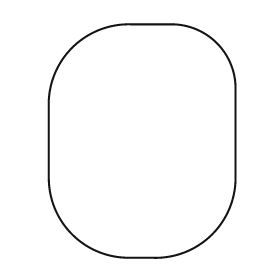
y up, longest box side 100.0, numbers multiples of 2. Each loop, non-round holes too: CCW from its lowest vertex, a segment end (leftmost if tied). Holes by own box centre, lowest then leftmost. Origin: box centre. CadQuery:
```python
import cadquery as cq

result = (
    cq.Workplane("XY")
    .moveTo(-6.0, -50.0)
    .lineTo(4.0, -50.0)
    .threePointArc((30.0, -40.0), (40.0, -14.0))
    .lineTo(40.0, 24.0)
    .threePointArc((32.0, 42.0), (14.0, 50.0))
    .lineTo(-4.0, 50.0)
    .threePointArc((-30.0, 40.0), (-40.0, 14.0))
    .lineTo(-40.0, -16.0)
    .threePointArc((-30.0, -40.0), (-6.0, -50.0))
    .close()
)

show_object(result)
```